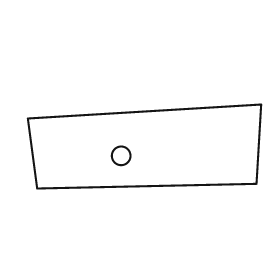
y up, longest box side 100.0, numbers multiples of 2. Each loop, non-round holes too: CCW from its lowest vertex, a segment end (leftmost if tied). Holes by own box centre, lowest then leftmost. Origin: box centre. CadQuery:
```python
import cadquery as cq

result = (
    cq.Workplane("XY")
    .moveTo(-46.0, -18.0)
    .lineTo(48.0, -16.0)
    .lineTo(50.0, 18.0)
    .lineTo(-50.0, 12.0)
    .close()
    .moveTo(-10.0, -4.0)
    .circle(4.0)
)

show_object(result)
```